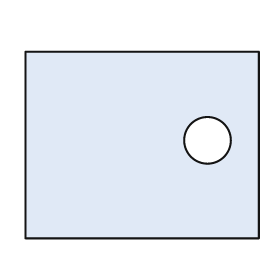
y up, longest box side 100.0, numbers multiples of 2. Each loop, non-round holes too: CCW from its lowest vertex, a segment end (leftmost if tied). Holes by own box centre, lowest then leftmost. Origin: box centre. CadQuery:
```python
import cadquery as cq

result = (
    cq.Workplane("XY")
    .moveTo(-50.0, -40.0)
    .lineTo(50.0, -40.0)
    .lineTo(50.0, 40.0)
    .lineTo(-50.0, 40.0)
    .close()
    .moveTo(28.0, 2.0)
    .circle(10.0)
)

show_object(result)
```